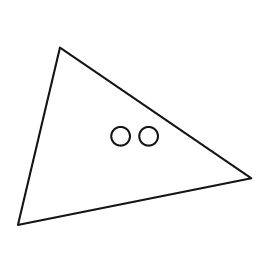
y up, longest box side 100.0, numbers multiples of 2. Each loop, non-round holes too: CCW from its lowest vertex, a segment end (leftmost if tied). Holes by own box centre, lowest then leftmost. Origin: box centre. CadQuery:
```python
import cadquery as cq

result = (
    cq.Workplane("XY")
    .moveTo(-50.0, -38.0)
    .lineTo(50.0, -18.0)
    .lineTo(-32.0, 38.0)
    .close()
    .moveTo(-6.0, 0.0)
    .circle(4.0)
    .moveTo(6.0, 0.0)
    .circle(4.0)
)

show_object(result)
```